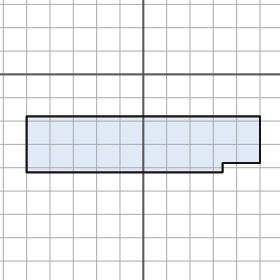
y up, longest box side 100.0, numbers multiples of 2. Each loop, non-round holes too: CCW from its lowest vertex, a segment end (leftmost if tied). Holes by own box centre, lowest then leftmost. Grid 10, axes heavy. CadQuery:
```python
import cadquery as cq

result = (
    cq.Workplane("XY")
    .moveTo(-50.0, -42.0)
    .lineTo(34.0, -42.0)
    .lineTo(34.0, -38.0)
    .lineTo(50.0, -38.0)
    .lineTo(50.0, -18.0)
    .lineTo(-50.0, -18.0)
    .close()
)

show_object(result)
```